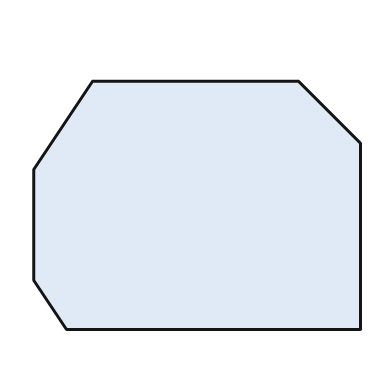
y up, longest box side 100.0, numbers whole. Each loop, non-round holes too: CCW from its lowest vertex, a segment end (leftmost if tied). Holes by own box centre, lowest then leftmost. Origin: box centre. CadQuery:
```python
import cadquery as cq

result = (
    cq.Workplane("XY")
    .moveTo(-40.0, -38.0)
    .lineTo(50.0, -38.0)
    .lineTo(50.0, 19.0)
    .lineTo(31.0, 38.0)
    .lineTo(-32.0, 38.0)
    .lineTo(-50.0, 11.0)
    .lineTo(-50.0, -23.0)
    .close()
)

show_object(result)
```